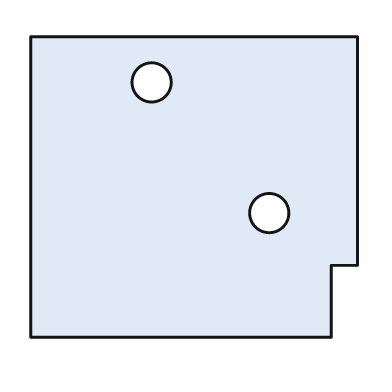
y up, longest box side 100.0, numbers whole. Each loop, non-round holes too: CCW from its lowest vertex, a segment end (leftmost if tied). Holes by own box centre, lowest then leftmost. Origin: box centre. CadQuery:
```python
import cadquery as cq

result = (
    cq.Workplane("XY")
    .moveTo(-50.0, -46.0)
    .lineTo(42.0, -46.0)
    .lineTo(42.0, -24.0)
    .lineTo(50.0, -24.0)
    .lineTo(50.0, 46.0)
    .lineTo(-50.0, 46.0)
    .close()
    .moveTo(23.0, -8.0)
    .circle(6.0)
    .moveTo(-13.0, 32.0)
    .circle(6.0)
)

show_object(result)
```